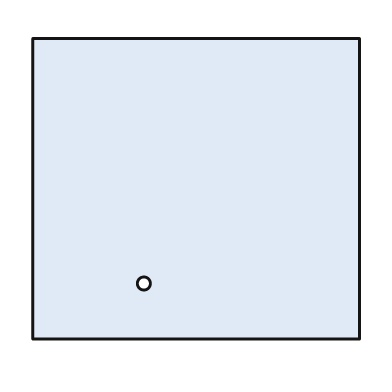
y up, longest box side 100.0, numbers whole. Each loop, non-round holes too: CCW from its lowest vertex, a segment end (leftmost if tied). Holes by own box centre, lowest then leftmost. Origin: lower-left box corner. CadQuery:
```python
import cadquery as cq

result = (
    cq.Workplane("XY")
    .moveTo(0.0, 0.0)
    .lineTo(100.0, 0.0)
    .lineTo(100.0, 92.0)
    .lineTo(0.0, 92.0)
    .close()
    .moveTo(34.0, 17.0)
    .circle(2.0)
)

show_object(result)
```